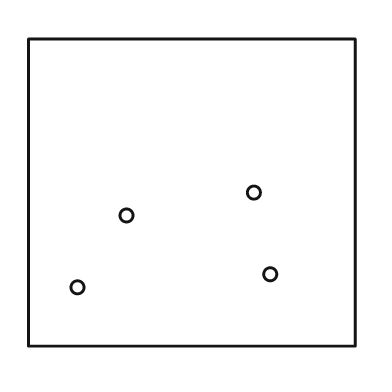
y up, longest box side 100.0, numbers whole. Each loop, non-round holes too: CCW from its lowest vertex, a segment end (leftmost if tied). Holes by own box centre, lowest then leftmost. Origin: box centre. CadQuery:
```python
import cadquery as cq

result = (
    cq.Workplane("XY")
    .moveTo(-50.0, -47.0)
    .lineTo(50.0, -47.0)
    .lineTo(50.0, 47.0)
    .lineTo(-50.0, 47.0)
    .close()
    .moveTo(-35.0, -29.0)
    .circle(2.0)
    .moveTo(24.0, -25.0)
    .circle(2.0)
    .moveTo(-20.0, -7.0)
    .circle(2.0)
    .moveTo(19.0, 0.0)
    .circle(2.0)
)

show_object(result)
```